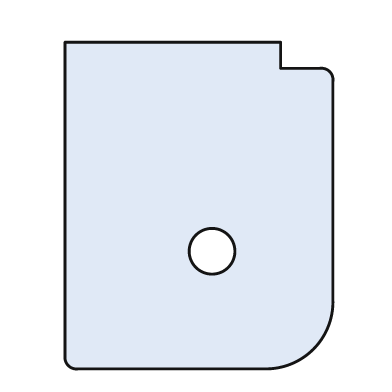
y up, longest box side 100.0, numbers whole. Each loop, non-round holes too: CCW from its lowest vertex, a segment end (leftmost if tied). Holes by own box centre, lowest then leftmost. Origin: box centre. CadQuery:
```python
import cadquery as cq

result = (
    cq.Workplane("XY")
    .moveTo(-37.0, -50.0)
    .lineTo(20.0, -50.0)
    .threePointArc((35.0, -44.0), (41.0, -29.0))
    .lineTo(41.0, 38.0)
    .threePointArc((40.0, 41.0), (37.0, 42.0))
    .lineTo(25.0, 42.0)
    .lineTo(25.0, 50.0)
    .lineTo(-41.0, 50.0)
    .lineTo(-41.0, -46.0)
    .threePointArc((-40.0, -49.0), (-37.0, -50.0))
    .close()
    .moveTo(4.0, -14.0)
    .circle(7.0)
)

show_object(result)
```